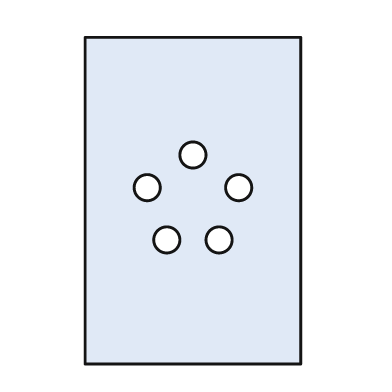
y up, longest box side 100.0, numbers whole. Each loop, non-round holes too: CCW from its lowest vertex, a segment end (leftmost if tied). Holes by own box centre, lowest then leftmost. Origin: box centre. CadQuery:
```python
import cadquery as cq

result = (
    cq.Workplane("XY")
    .moveTo(-33.0, -50.0)
    .lineTo(33.0, -50.0)
    .lineTo(33.0, 50.0)
    .lineTo(-33.0, 50.0)
    .close()
    .moveTo(-8.0, -12.0)
    .circle(4.0)
    .moveTo(8.0, -12.0)
    .circle(4.0)
    .moveTo(-14.0, 4.0)
    .circle(4.0)
    .moveTo(14.0, 4.0)
    .circle(4.0)
    .moveTo(0.0, 14.0)
    .circle(4.0)
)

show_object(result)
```